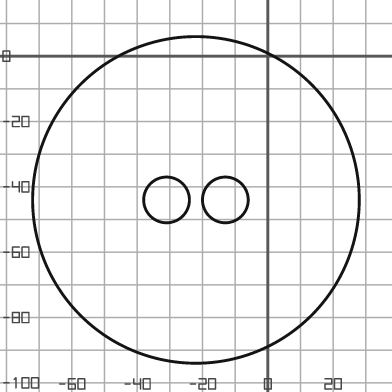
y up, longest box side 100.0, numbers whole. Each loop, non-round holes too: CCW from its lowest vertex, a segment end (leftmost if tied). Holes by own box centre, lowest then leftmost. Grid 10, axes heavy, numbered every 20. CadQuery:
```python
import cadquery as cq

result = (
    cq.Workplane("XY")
    .moveTo(-22.0, -44.0)
    .circle(50.0)
    .moveTo(-31.0, -44.0)
    .circle(7.0)
    .moveTo(-13.0, -44.0)
    .circle(7.0)
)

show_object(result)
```